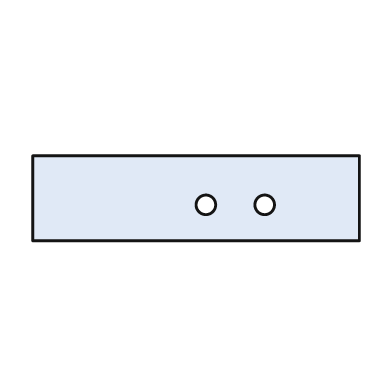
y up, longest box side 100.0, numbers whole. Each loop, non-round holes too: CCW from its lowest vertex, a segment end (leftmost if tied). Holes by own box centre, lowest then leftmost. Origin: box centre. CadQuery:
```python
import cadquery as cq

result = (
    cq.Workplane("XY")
    .moveTo(-50.0, -13.0)
    .lineTo(50.0, -13.0)
    .lineTo(50.0, 13.0)
    .lineTo(-50.0, 13.0)
    .close()
    .moveTo(3.0, -2.0)
    .circle(3.0)
    .moveTo(21.0, -2.0)
    .circle(3.0)
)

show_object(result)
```